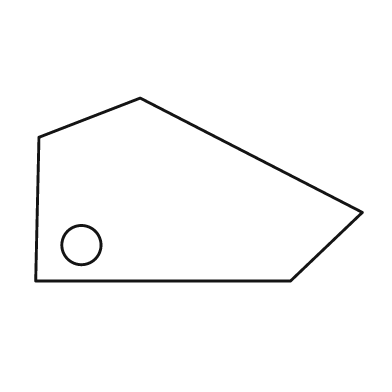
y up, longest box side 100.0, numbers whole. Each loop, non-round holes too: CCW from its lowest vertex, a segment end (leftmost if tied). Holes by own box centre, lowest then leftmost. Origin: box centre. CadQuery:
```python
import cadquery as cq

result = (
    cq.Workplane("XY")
    .moveTo(-50.0, -28.0)
    .lineTo(28.0, -28.0)
    .lineTo(50.0, -7.0)
    .lineTo(-18.0, 28.0)
    .lineTo(-49.0, 16.0)
    .close()
    .moveTo(-36.0, -17.0)
    .circle(6.0)
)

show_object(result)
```